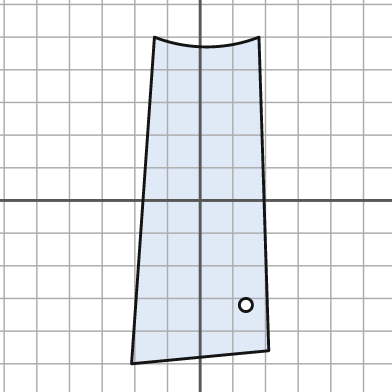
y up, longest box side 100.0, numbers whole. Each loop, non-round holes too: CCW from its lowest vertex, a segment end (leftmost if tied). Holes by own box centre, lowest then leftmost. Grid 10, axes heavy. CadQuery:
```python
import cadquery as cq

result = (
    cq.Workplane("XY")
    .moveTo(-21.0, -50.0)
    .lineTo(21.0, -46.0)
    .lineTo(18.0, 50.0)
    .threePointArc((2.0, 47.0), (-14.0, 50.0))
    .close()
    .moveTo(14.0, -32.0)
    .circle(2.0)
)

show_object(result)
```